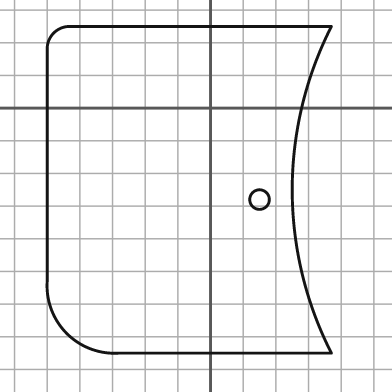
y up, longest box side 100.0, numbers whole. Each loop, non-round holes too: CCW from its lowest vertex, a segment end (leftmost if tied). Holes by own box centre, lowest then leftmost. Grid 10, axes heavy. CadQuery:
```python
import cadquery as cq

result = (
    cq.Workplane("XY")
    .moveTo(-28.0, -75.0)
    .lineTo(37.0, -75.0)
    .threePointArc((25.0, -25.0), (37.0, 25.0))
    .lineTo(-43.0, 25.0)
    .threePointArc((-48.0, 23.0), (-50.0, 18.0))
    .lineTo(-50.0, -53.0)
    .threePointArc((-44.0, -69.0), (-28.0, -75.0))
    .close()
    .moveTo(15.0, -28.0)
    .circle(3.0)
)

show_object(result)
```